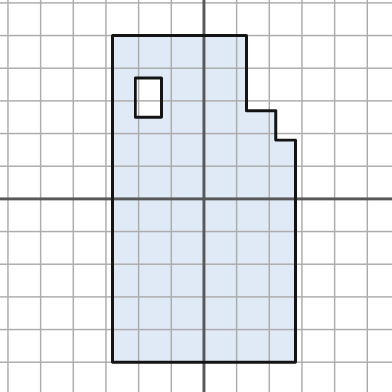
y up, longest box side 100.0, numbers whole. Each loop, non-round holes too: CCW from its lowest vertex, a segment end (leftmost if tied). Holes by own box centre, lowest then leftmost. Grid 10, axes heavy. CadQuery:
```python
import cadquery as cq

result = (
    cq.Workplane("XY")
    .moveTo(-28.0, -50.0)
    .lineTo(28.0, -50.0)
    .lineTo(28.0, 18.0)
    .lineTo(22.0, 18.0)
    .lineTo(22.0, 27.0)
    .lineTo(13.0, 27.0)
    .lineTo(13.0, 50.0)
    .lineTo(-28.0, 50.0)
    .close()
    .moveTo(-21.0, 25.0)
    .lineTo(-13.0, 25.0)
    .lineTo(-13.0, 37.0)
    .lineTo(-21.0, 37.0)
    .close()
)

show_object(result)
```